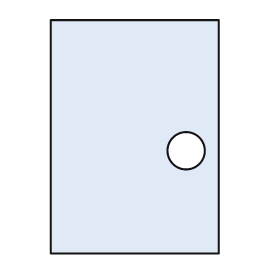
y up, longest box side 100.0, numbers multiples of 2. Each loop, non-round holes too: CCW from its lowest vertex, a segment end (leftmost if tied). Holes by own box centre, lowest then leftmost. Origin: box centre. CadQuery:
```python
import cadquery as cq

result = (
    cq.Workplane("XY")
    .moveTo(-36.0, -50.0)
    .lineTo(36.0, -50.0)
    .lineTo(36.0, 50.0)
    .lineTo(-36.0, 50.0)
    .close()
    .moveTo(22.0, -6.0)
    .circle(8.0)
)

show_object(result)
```